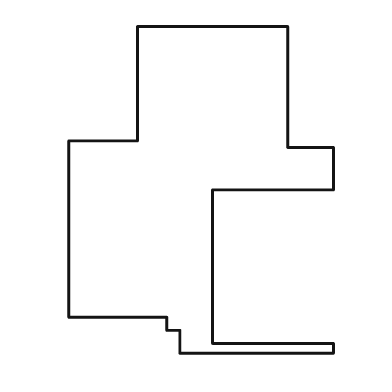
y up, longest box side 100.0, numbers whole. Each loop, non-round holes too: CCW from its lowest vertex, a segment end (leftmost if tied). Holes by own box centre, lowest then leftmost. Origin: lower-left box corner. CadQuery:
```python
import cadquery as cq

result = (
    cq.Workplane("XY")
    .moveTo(34.0, 0.0)
    .lineTo(81.0, 0.0)
    .lineTo(81.0, 3.0)
    .lineTo(44.0, 3.0)
    .lineTo(44.0, 50.0)
    .lineTo(81.0, 50.0)
    .lineTo(81.0, 63.0)
    .lineTo(67.0, 63.0)
    .lineTo(67.0, 100.0)
    .lineTo(21.0, 100.0)
    .lineTo(21.0, 65.0)
    .lineTo(0.0, 65.0)
    .lineTo(0.0, 11.0)
    .lineTo(30.0, 11.0)
    .lineTo(30.0, 7.0)
    .lineTo(34.0, 7.0)
    .close()
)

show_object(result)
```